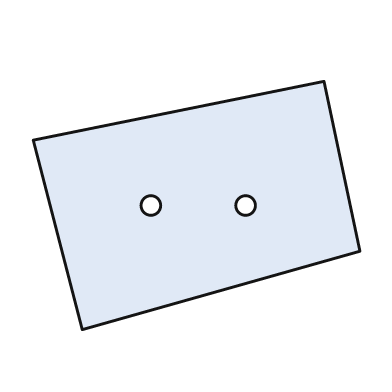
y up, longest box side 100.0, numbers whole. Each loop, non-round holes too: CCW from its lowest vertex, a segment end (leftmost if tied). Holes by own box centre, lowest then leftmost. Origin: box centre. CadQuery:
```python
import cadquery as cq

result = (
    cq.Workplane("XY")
    .moveTo(-35.0, -38.0)
    .lineTo(50.0, -14.0)
    .lineTo(39.0, 38.0)
    .lineTo(-50.0, 20.0)
    .close()
    .moveTo(-14.0, 0.0)
    .circle(3.0)
    .moveTo(15.0, 0.0)
    .circle(3.0)
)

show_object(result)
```